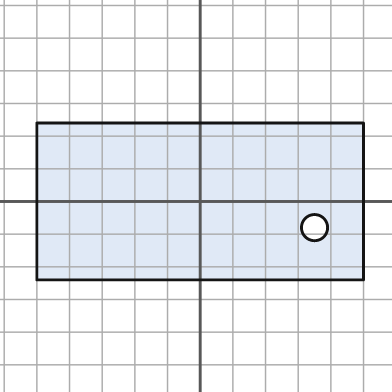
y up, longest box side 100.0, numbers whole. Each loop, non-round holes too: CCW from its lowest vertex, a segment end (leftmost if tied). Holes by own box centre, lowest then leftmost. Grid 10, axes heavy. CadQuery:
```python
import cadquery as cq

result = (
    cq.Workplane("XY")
    .moveTo(-50.0, -24.0)
    .lineTo(50.0, -24.0)
    .lineTo(50.0, 24.0)
    .lineTo(-50.0, 24.0)
    .close()
    .moveTo(35.0, -8.0)
    .circle(4.0)
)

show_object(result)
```